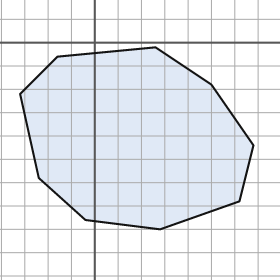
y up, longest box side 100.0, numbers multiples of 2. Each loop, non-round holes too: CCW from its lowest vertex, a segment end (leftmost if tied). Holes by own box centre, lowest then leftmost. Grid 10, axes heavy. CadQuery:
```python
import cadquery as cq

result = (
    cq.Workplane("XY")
    .moveTo(28.0, -80.0)
    .lineTo(62.0, -68.0)
    .lineTo(68.0, -44.0)
    .lineTo(50.0, -18.0)
    .lineTo(26.0, -2.0)
    .lineTo(-16.0, -6.0)
    .lineTo(-32.0, -22.0)
    .lineTo(-24.0, -58.0)
    .lineTo(-4.0, -76.0)
    .close()
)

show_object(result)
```